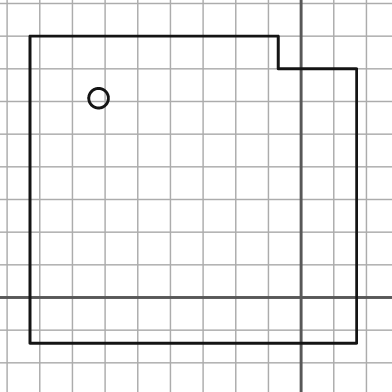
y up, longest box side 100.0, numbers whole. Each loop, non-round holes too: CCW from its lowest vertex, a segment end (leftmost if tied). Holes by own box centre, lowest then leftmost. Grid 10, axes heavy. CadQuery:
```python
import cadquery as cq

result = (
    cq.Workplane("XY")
    .moveTo(-83.0, -14.0)
    .lineTo(17.0, -14.0)
    .lineTo(17.0, 70.0)
    .lineTo(-7.0, 70.0)
    .lineTo(-7.0, 80.0)
    .lineTo(-83.0, 80.0)
    .close()
    .moveTo(-62.0, 61.0)
    .circle(3.0)
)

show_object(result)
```